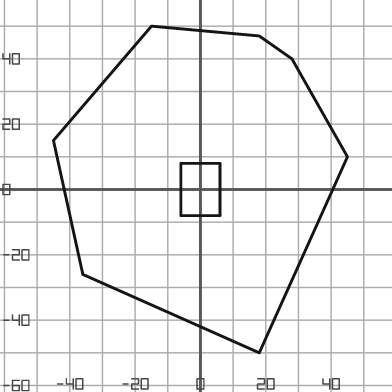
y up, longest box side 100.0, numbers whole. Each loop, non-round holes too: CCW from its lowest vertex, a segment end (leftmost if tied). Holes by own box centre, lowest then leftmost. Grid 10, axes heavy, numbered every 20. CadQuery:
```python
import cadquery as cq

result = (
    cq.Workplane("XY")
    .moveTo(18.0, -50.0)
    .lineTo(45.0, 10.0)
    .lineTo(28.0, 40.0)
    .lineTo(18.0, 47.0)
    .lineTo(-15.0, 50.0)
    .lineTo(-45.0, 15.0)
    .lineTo(-36.0, -26.0)
    .close()
    .moveTo(-6.0, -8.0)
    .lineTo(6.0, -8.0)
    .lineTo(6.0, 8.0)
    .lineTo(-6.0, 8.0)
    .close()
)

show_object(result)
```